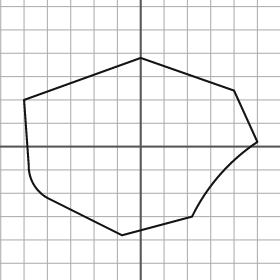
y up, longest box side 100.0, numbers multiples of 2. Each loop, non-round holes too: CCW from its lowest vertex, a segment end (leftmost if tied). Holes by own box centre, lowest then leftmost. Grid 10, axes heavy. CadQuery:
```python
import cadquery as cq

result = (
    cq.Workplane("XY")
    .moveTo(-8.0, -38.0)
    .lineTo(22.0, -30.0)
    .threePointArc((34.0, -12.0), (50.0, 2.0))
    .lineTo(40.0, 24.0)
    .lineTo(0.0, 38.0)
    .lineTo(-50.0, 20.0)
    .lineTo(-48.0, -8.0)
    .threePointArc((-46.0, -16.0), (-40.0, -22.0))
    .close()
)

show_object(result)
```